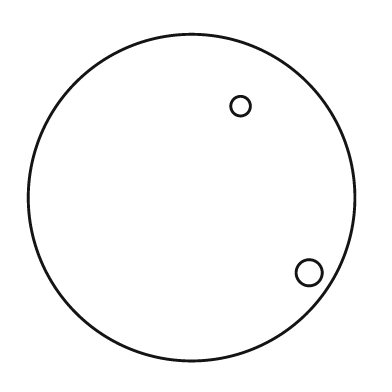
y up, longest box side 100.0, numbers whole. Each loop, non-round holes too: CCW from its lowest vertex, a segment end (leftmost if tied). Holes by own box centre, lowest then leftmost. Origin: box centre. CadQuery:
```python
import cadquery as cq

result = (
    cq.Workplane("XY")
    .moveTo(0.0, 0.0)
    .circle(50.0)
    .moveTo(36.0, -23.0)
    .circle(4.0)
    .moveTo(15.0, 28.0)
    .circle(3.0)
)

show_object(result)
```